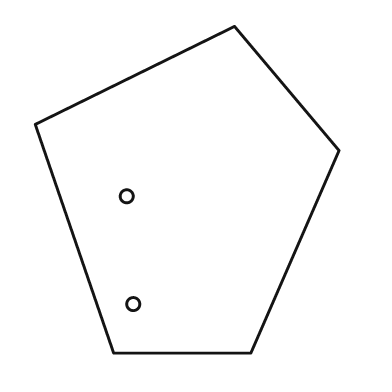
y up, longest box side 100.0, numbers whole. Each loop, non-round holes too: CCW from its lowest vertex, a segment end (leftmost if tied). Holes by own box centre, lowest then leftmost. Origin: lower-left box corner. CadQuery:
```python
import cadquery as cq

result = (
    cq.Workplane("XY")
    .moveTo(24.0, 0.0)
    .lineTo(66.0, 0.0)
    .lineTo(93.0, 62.0)
    .lineTo(61.0, 100.0)
    .lineTo(0.0, 70.0)
    .close()
    .moveTo(30.0, 15.0)
    .circle(2.0)
    .moveTo(28.0, 48.0)
    .circle(2.0)
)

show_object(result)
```